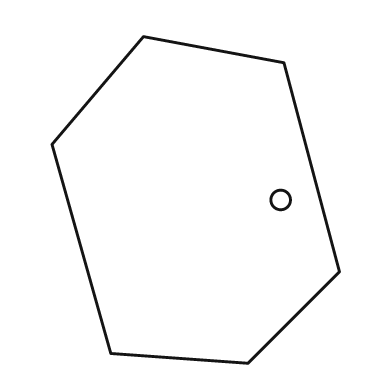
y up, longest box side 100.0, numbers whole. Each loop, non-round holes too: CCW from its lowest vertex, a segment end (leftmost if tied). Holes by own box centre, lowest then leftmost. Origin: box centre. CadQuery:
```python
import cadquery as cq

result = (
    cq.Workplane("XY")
    .moveTo(16.0, -50.0)
    .lineTo(44.0, -22.0)
    .lineTo(27.0, 42.0)
    .lineTo(-16.0, 50.0)
    .lineTo(-44.0, 17.0)
    .lineTo(-26.0, -47.0)
    .close()
    .moveTo(26.0, 0.0)
    .circle(3.0)
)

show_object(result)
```